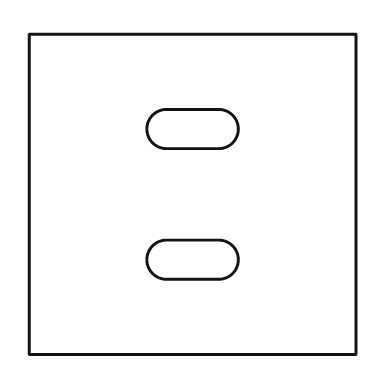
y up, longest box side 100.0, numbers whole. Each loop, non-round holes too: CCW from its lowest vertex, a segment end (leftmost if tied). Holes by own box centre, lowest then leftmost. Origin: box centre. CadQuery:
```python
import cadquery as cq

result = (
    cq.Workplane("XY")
    .moveTo(-50.0, -49.0)
    .lineTo(50.0, -49.0)
    .lineTo(50.0, 49.0)
    .lineTo(-50.0, 49.0)
    .close()
    .moveTo(-8.0, -26.0)
    .lineTo(8.0, -26.0)
    .threePointArc((14.0, -20.0), (8.0, -14.0))
    .lineTo(-8.0, -14.0)
    .threePointArc((-14.0, -20.0), (-8.0, -26.0))
    .close()
    .moveTo(-8.0, 14.0)
    .lineTo(8.0, 14.0)
    .threePointArc((14.0, 20.0), (8.0, 26.0))
    .lineTo(-8.0, 26.0)
    .threePointArc((-14.0, 20.0), (-8.0, 14.0))
    .close()
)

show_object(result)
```